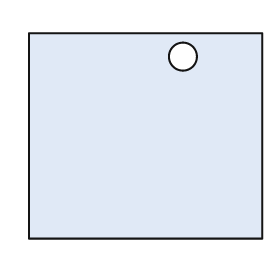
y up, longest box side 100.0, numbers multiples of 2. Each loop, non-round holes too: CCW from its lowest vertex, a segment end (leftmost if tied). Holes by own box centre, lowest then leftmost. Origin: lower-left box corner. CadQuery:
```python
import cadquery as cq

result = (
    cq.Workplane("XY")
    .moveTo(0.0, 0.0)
    .lineTo(100.0, 0.0)
    .lineTo(100.0, 88.0)
    .lineTo(0.0, 88.0)
    .close()
    .moveTo(66.0, 78.0)
    .circle(6.0)
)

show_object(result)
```